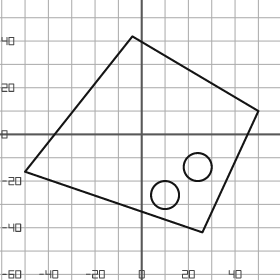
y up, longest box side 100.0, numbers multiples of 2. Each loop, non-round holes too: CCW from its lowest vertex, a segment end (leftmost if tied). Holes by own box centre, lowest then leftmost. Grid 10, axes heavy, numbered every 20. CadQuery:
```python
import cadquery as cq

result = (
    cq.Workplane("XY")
    .moveTo(26.0, -42.0)
    .lineTo(50.0, 10.0)
    .lineTo(-4.0, 42.0)
    .lineTo(-50.0, -16.0)
    .close()
    .moveTo(10.0, -26.0)
    .circle(6.0)
    .moveTo(24.0, -14.0)
    .circle(6.0)
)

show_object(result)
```